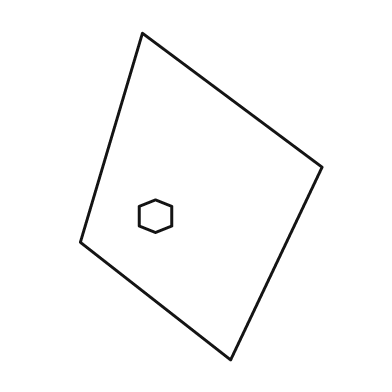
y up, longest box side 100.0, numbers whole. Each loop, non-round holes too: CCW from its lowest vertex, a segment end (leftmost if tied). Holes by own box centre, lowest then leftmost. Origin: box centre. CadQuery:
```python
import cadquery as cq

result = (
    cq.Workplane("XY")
    .moveTo(9.0, -50.0)
    .lineTo(37.0, 9.0)
    .lineTo(-18.0, 50.0)
    .lineTo(-37.0, -14.0)
    .close()
    .moveTo(-14.0, -11.0)
    .lineTo(-9.0, -9.0)
    .lineTo(-9.0, -3.0)
    .lineTo(-14.0, -1.0)
    .lineTo(-19.0, -3.0)
    .lineTo(-19.0, -9.0)
    .close()
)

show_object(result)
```